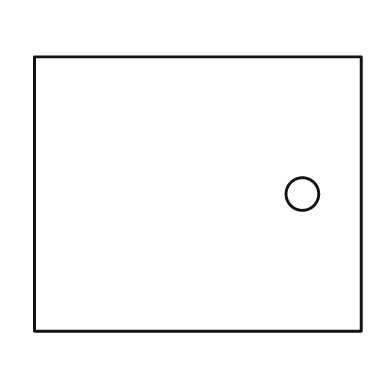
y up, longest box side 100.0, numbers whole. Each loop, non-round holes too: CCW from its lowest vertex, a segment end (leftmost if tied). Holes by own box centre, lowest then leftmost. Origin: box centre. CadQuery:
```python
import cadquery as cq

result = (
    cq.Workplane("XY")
    .moveTo(-50.0, -42.0)
    .lineTo(50.0, -42.0)
    .lineTo(50.0, 42.0)
    .lineTo(-50.0, 42.0)
    .close()
    .moveTo(32.0, 0.0)
    .circle(5.0)
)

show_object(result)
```